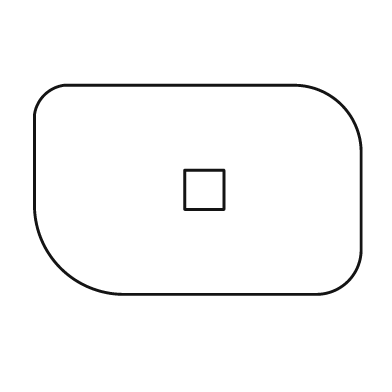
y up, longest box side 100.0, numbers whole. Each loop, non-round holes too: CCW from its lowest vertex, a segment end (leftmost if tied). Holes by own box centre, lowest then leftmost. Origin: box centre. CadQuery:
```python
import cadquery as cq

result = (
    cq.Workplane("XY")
    .moveTo(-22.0, -32.0)
    .lineTo(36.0, -32.0)
    .threePointArc((46.0, -28.0), (50.0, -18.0))
    .lineTo(50.0, 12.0)
    .threePointArc((44.0, 26.0), (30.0, 32.0))
    .lineTo(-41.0, 32.0)
    .threePointArc((-47.0, 29.0), (-50.0, 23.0))
    .lineTo(-50.0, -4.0)
    .threePointArc((-42.0, -24.0), (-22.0, -32.0))
    .close()
    .moveTo(-4.0, -6.0)
    .lineTo(8.0, -6.0)
    .lineTo(8.0, 6.0)
    .lineTo(-4.0, 6.0)
    .close()
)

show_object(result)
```